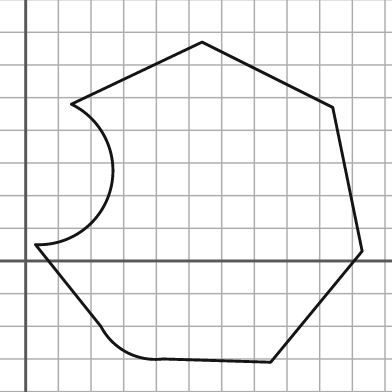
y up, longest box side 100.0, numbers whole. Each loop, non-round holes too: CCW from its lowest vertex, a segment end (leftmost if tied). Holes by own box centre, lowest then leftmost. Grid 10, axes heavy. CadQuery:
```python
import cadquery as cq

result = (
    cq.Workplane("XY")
    .moveTo(75.0, -31.0)
    .lineTo(103.0, 3.0)
    .lineTo(94.0, 47.0)
    .lineTo(54.0, 67.0)
    .lineTo(14.0, 48.0)
    .threePointArc((26.0, 22.0), (3.0, 5.0))
    .lineTo(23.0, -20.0)
    .threePointArc((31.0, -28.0), (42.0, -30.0))
    .close()
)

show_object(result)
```